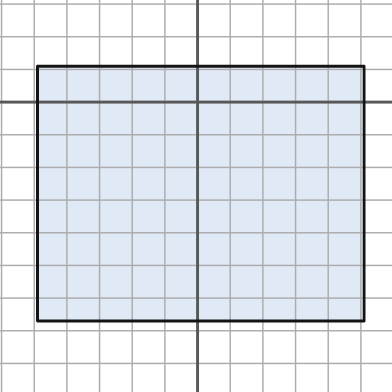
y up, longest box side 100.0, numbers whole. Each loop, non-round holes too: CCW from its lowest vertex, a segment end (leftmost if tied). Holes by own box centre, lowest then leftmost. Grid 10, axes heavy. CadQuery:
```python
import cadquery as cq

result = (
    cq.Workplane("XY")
    .moveTo(-49.0, -67.0)
    .lineTo(51.0, -67.0)
    .lineTo(51.0, 11.0)
    .lineTo(-49.0, 11.0)
    .close()
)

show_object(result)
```